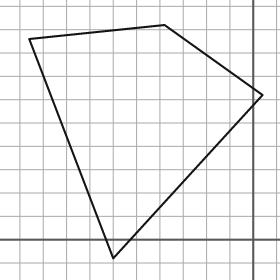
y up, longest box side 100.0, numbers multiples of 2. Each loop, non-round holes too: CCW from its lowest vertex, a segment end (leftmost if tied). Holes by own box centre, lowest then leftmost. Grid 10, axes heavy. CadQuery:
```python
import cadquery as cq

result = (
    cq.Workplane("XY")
    .moveTo(-60.0, -8.0)
    .lineTo(4.0, 62.0)
    .lineTo(-38.0, 92.0)
    .lineTo(-96.0, 86.0)
    .close()
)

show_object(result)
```